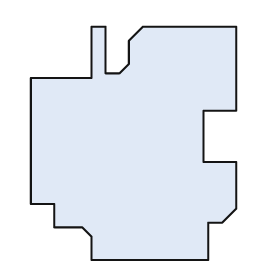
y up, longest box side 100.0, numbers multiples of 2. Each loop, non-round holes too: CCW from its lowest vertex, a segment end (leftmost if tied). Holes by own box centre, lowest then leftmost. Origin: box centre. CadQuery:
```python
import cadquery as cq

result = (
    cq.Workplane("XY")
    .moveTo(-18.0, -50.0)
    .lineTo(32.0, -50.0)
    .lineTo(32.0, -34.0)
    .lineTo(38.0, -34.0)
    .lineTo(44.0, -28.0)
    .lineTo(44.0, -8.0)
    .lineTo(30.0, -8.0)
    .lineTo(30.0, 14.0)
    .lineTo(44.0, 14.0)
    .lineTo(44.0, 50.0)
    .lineTo(4.0, 50.0)
    .lineTo(-2.0, 44.0)
    .lineTo(-2.0, 34.0)
    .lineTo(-6.0, 30.0)
    .lineTo(-12.0, 30.0)
    .lineTo(-12.0, 50.0)
    .lineTo(-18.0, 50.0)
    .lineTo(-18.0, 28.0)
    .lineTo(-44.0, 28.0)
    .lineTo(-44.0, -26.0)
    .lineTo(-34.0, -26.0)
    .lineTo(-34.0, -36.0)
    .lineTo(-22.0, -36.0)
    .lineTo(-18.0, -40.0)
    .close()
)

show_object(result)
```